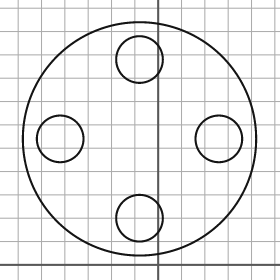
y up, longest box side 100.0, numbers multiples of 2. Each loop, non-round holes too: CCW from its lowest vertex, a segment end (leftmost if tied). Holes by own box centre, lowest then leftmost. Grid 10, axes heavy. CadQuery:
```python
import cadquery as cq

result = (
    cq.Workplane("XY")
    .moveTo(-8.0, 54.0)
    .circle(50.0)
    .moveTo(-8.0, 20.0)
    .circle(10.0)
    .moveTo(-42.0, 54.0)
    .circle(10.0)
    .moveTo(26.0, 54.0)
    .circle(10.0)
    .moveTo(-8.0, 88.0)
    .circle(10.0)
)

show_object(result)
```